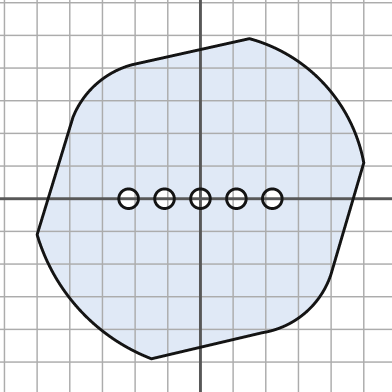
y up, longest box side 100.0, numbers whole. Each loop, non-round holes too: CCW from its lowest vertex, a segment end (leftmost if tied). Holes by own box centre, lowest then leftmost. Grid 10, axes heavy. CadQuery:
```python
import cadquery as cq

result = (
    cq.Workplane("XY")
    .moveTo(-15.0, -49.0)
    .lineTo(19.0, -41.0)
    .threePointArc((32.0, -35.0), (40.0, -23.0))
    .lineTo(50.0, 11.0)
    .threePointArc((38.0, 35.0), (15.0, 49.0))
    .lineTo(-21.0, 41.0)
    .threePointArc((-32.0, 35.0), (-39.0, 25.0))
    .lineTo(-50.0, -11.0)
    .threePointArc((-37.0, -34.0), (-15.0, -49.0))
    .close()
    .moveTo(-22.0, 0.0)
    .circle(3.0)
    .moveTo(-11.0, 0.0)
    .circle(3.0)
    .moveTo(0.0, 0.0)
    .circle(3.0)
    .moveTo(11.0, 0.0)
    .circle(3.0)
    .moveTo(22.0, 0.0)
    .circle(3.0)
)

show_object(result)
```